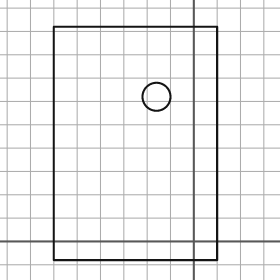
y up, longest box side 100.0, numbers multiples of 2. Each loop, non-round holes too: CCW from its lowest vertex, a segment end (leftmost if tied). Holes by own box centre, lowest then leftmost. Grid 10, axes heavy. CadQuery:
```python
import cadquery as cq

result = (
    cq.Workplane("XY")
    .moveTo(-60.0, -8.0)
    .lineTo(10.0, -8.0)
    .lineTo(10.0, 92.0)
    .lineTo(-60.0, 92.0)
    .close()
    .moveTo(-16.0, 62.0)
    .circle(6.0)
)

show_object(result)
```